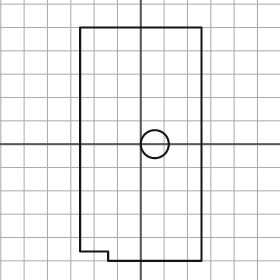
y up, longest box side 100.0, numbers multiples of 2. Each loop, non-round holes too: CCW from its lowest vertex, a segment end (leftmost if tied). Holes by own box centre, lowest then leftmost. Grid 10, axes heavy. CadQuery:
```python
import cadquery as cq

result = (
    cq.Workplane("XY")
    .moveTo(-14.0, -50.0)
    .lineTo(26.0, -50.0)
    .lineTo(26.0, 50.0)
    .lineTo(-26.0, 50.0)
    .lineTo(-26.0, -46.0)
    .lineTo(-14.0, -46.0)
    .close()
    .moveTo(6.0, 0.0)
    .circle(6.0)
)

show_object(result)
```